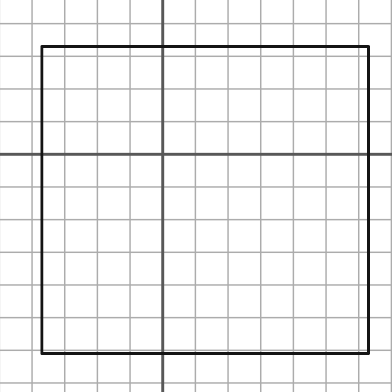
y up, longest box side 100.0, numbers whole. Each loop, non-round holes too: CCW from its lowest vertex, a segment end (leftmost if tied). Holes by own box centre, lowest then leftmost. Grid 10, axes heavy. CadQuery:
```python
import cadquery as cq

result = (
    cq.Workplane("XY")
    .moveTo(-37.0, -61.0)
    .lineTo(63.0, -61.0)
    .lineTo(63.0, 33.0)
    .lineTo(-37.0, 33.0)
    .close()
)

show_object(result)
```